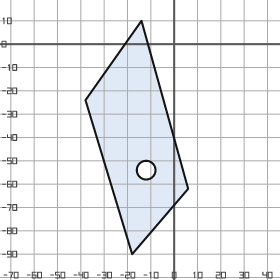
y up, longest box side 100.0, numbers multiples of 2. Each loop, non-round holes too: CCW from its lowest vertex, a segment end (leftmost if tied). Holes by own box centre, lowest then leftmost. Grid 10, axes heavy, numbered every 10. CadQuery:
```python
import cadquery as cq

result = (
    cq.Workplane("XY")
    .moveTo(-18.0, -90.0)
    .lineTo(6.0, -62.0)
    .lineTo(-14.0, 10.0)
    .lineTo(-38.0, -24.0)
    .close()
    .moveTo(-12.0, -54.0)
    .circle(4.0)
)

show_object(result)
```